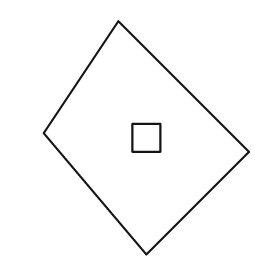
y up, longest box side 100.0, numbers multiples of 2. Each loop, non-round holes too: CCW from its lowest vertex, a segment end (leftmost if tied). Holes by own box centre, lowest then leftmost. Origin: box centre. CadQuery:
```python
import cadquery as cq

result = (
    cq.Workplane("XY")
    .moveTo(0.0, -50.0)
    .lineTo(44.0, -6.0)
    .lineTo(-12.0, 50.0)
    .lineTo(-44.0, 2.0)
    .close()
    .moveTo(-6.0, -6.0)
    .lineTo(6.0, -6.0)
    .lineTo(6.0, 6.0)
    .lineTo(-6.0, 6.0)
    .close()
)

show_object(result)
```